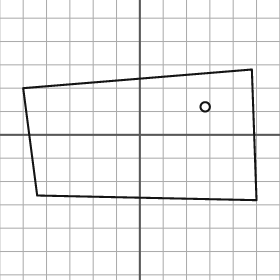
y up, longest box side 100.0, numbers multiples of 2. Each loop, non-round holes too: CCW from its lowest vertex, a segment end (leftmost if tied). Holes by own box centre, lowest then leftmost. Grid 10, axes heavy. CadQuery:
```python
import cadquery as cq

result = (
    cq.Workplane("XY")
    .moveTo(50.0, -28.0)
    .lineTo(48.0, 28.0)
    .lineTo(-50.0, 20.0)
    .lineTo(-44.0, -26.0)
    .close()
    .moveTo(28.0, 12.0)
    .circle(2.0)
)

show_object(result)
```